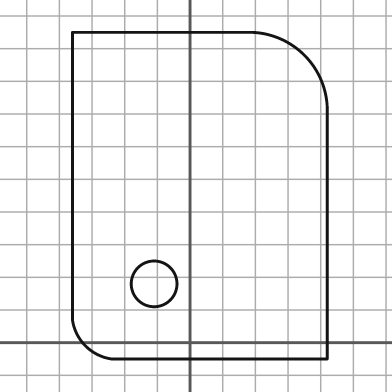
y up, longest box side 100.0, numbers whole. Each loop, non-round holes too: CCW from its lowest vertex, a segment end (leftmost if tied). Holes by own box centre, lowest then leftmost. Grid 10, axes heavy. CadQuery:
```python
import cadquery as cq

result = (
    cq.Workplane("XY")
    .moveTo(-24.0, -5.0)
    .lineTo(42.0, -5.0)
    .lineTo(42.0, 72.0)
    .threePointArc((35.0, 88.0), (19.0, 95.0))
    .lineTo(-36.0, 95.0)
    .lineTo(-36.0, 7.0)
    .threePointArc((-32.0, -1.0), (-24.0, -5.0))
    .close()
    .moveTo(-11.0, 18.0)
    .circle(7.0)
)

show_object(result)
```